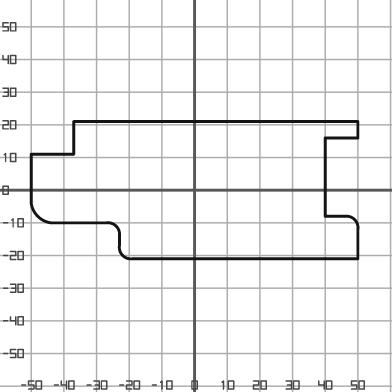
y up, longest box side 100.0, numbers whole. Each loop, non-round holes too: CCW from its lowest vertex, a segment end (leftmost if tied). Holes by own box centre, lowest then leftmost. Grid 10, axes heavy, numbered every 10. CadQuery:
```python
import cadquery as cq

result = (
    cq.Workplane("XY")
    .moveTo(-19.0, -21.0)
    .lineTo(50.0, -21.0)
    .lineTo(50.0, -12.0)
    .threePointArc((49.0, -9.0), (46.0, -8.0))
    .lineTo(40.0, -8.0)
    .lineTo(40.0, 16.0)
    .lineTo(50.0, 16.0)
    .lineTo(50.0, 21.0)
    .lineTo(-37.0, 21.0)
    .lineTo(-37.0, 11.0)
    .lineTo(-50.0, 11.0)
    .lineTo(-50.0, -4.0)
    .threePointArc((-48.0, -8.0), (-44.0, -10.0))
    .lineTo(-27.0, -10.0)
    .threePointArc((-24.0, -11.0), (-23.0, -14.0))
    .lineTo(-23.0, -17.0)
    .threePointArc((-22.0, -20.0), (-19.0, -21.0))
    .close()
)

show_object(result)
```